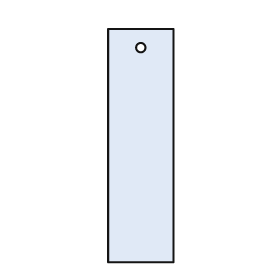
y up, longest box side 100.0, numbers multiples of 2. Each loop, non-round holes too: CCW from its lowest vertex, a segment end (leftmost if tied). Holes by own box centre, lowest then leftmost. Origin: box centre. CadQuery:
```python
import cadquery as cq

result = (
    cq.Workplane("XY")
    .moveTo(-14.0, -50.0)
    .lineTo(14.0, -50.0)
    .lineTo(14.0, 50.0)
    .lineTo(-14.0, 50.0)
    .close()
    .moveTo(0.0, 42.0)
    .circle(2.0)
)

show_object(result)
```